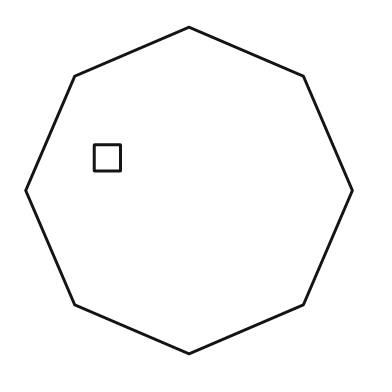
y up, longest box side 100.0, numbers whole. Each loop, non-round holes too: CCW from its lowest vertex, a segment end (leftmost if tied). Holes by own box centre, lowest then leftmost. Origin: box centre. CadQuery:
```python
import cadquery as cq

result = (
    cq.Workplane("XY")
    .moveTo(0.0, -50.0)
    .lineTo(35.0, -35.0)
    .lineTo(50.0, 0.0)
    .lineTo(35.0, 35.0)
    .lineTo(0.0, 50.0)
    .lineTo(-35.0, 35.0)
    .lineTo(-50.0, 0.0)
    .lineTo(-35.0, -35.0)
    .close()
    .moveTo(-29.0, 6.0)
    .lineTo(-21.0, 6.0)
    .lineTo(-21.0, 14.0)
    .lineTo(-29.0, 14.0)
    .close()
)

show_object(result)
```